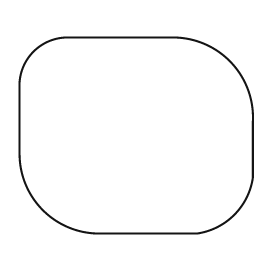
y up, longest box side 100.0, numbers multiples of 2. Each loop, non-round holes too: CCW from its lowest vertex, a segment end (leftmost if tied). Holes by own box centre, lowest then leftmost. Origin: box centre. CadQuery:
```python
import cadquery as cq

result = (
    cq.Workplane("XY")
    .moveTo(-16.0, -42.0)
    .lineTo(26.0, -42.0)
    .threePointArc((42.0, -34.0), (50.0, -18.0))
    .lineTo(50.0, 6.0)
    .threePointArc((40.0, 32.0), (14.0, 42.0))
    .lineTo(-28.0, 42.0)
    .threePointArc((-44.0, 36.0), (-50.0, 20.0))
    .lineTo(-50.0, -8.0)
    .threePointArc((-40.0, -32.0), (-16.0, -42.0))
    .close()
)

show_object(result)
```